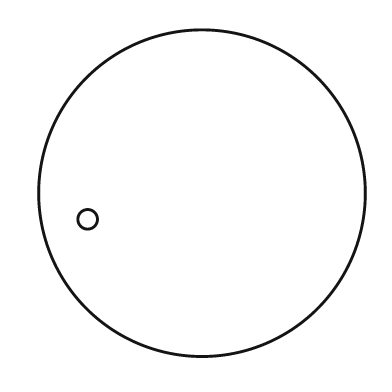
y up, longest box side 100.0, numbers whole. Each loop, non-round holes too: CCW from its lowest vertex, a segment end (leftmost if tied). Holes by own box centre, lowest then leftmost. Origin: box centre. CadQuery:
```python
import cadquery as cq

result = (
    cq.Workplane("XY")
    .moveTo(0.0, 0.0)
    .circle(50.0)
    .moveTo(-35.0, -8.0)
    .circle(3.0)
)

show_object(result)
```